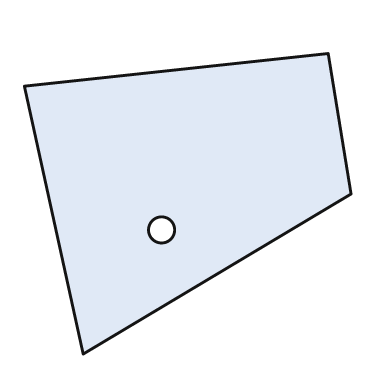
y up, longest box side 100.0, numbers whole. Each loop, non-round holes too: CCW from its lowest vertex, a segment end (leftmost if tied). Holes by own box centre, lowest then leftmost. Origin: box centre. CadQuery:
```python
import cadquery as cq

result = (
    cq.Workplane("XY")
    .moveTo(-32.0, -46.0)
    .lineTo(50.0, 3.0)
    .lineTo(43.0, 46.0)
    .lineTo(-50.0, 36.0)
    .close()
    .moveTo(-8.0, -8.0)
    .circle(4.0)
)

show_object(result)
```